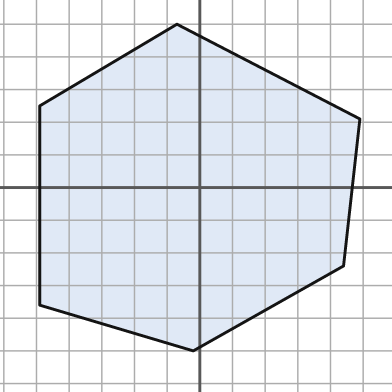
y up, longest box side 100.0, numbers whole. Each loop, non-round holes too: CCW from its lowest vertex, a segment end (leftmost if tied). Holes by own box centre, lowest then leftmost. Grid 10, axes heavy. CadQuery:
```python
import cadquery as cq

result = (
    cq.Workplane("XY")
    .moveTo(-2.0, -50.0)
    .lineTo(44.0, -24.0)
    .lineTo(49.0, 21.0)
    .lineTo(-7.0, 50.0)
    .lineTo(-49.0, 25.0)
    .lineTo(-49.0, -36.0)
    .close()
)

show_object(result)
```